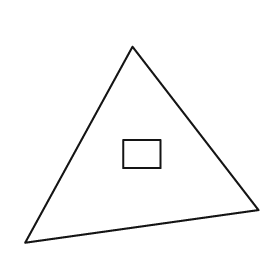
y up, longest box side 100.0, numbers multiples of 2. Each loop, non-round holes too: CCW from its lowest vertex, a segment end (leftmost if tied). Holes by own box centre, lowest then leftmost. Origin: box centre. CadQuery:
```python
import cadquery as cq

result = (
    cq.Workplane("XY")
    .moveTo(-50.0, -42.0)
    .lineTo(50.0, -28.0)
    .lineTo(-4.0, 42.0)
    .close()
    .moveTo(-8.0, -10.0)
    .lineTo(8.0, -10.0)
    .lineTo(8.0, 2.0)
    .lineTo(-8.0, 2.0)
    .close()
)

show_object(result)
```